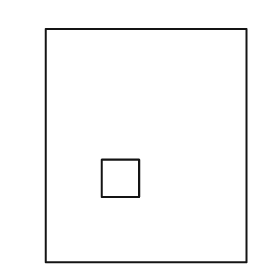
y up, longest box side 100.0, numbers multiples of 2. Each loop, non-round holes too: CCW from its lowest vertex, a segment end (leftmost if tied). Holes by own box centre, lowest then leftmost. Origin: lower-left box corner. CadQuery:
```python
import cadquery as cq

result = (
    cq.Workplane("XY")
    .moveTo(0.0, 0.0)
    .lineTo(86.0, 0.0)
    .lineTo(86.0, 100.0)
    .lineTo(0.0, 100.0)
    .close()
    .moveTo(24.0, 28.0)
    .lineTo(40.0, 28.0)
    .lineTo(40.0, 44.0)
    .lineTo(24.0, 44.0)
    .close()
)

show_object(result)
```